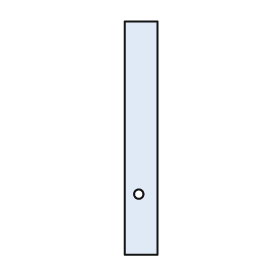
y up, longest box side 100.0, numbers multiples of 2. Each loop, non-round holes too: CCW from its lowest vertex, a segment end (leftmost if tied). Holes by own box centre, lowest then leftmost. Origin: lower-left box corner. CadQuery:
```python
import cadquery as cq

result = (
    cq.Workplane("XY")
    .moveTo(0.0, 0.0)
    .lineTo(14.0, 0.0)
    .lineTo(14.0, 100.0)
    .lineTo(0.0, 100.0)
    .close()
    .moveTo(6.0, 26.0)
    .circle(2.0)
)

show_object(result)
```